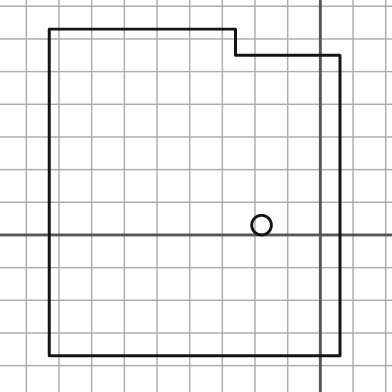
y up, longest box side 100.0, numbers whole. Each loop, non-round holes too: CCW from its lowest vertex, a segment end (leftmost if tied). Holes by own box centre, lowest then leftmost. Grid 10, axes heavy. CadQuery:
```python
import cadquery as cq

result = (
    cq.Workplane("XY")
    .moveTo(-83.0, -37.0)
    .lineTo(6.0, -37.0)
    .lineTo(6.0, 55.0)
    .lineTo(-26.0, 55.0)
    .lineTo(-26.0, 63.0)
    .lineTo(-83.0, 63.0)
    .close()
    .moveTo(-18.0, 3.0)
    .circle(3.0)
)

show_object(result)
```